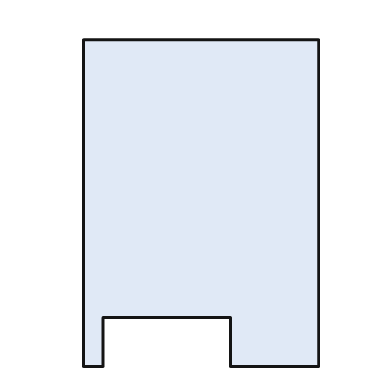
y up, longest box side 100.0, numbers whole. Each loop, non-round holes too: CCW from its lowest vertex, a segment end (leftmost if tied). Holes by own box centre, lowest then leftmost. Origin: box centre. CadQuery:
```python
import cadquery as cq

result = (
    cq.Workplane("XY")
    .moveTo(-36.0, -50.0)
    .lineTo(-30.0, -50.0)
    .lineTo(-30.0, -35.0)
    .lineTo(9.0, -35.0)
    .lineTo(9.0, -50.0)
    .lineTo(36.0, -50.0)
    .lineTo(36.0, 50.0)
    .lineTo(-36.0, 50.0)
    .close()
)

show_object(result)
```